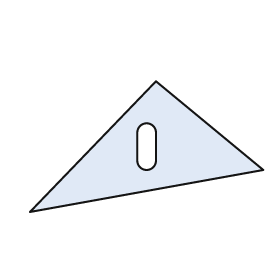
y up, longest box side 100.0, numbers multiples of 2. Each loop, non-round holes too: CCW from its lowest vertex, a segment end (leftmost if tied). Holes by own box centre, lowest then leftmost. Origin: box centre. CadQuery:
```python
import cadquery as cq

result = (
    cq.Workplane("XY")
    .moveTo(-50.0, -28.0)
    .lineTo(50.0, -10.0)
    .lineTo(4.0, 28.0)
    .close()
    .moveTo(-4.0, -6.0)
    .threePointArc((0.0, -10.0), (4.0, -6.0))
    .lineTo(4.0, 6.0)
    .threePointArc((0.0, 10.0), (-4.0, 6.0))
    .close()
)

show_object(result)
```